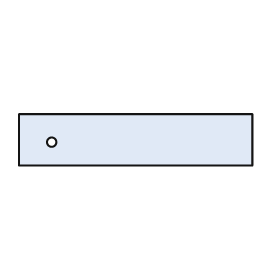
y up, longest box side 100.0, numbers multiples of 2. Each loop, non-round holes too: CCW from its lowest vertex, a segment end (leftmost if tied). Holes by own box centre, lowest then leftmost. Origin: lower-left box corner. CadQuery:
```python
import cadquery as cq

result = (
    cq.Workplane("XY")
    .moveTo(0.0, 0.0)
    .lineTo(100.0, 0.0)
    .lineTo(100.0, 22.0)
    .lineTo(0.0, 22.0)
    .close()
    .moveTo(14.0, 10.0)
    .circle(2.0)
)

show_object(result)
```